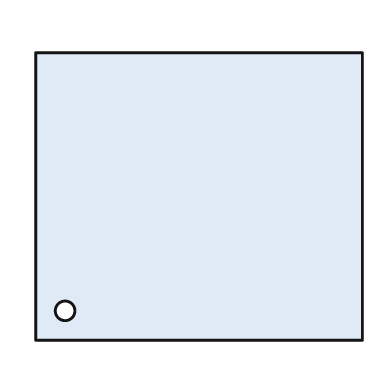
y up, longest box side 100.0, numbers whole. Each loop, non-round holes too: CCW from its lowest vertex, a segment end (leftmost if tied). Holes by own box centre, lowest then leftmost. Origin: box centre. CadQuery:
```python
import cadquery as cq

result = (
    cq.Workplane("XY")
    .moveTo(-50.0, -44.0)
    .lineTo(50.0, -44.0)
    .lineTo(50.0, 44.0)
    .lineTo(-50.0, 44.0)
    .close()
    .moveTo(-41.0, -35.0)
    .circle(3.0)
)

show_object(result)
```